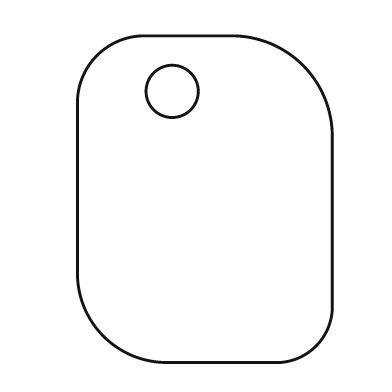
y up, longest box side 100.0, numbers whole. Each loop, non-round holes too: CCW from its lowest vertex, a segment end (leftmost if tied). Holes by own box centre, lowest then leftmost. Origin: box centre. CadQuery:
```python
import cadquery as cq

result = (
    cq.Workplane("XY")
    .moveTo(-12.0, -50.0)
    .lineTo(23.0, -50.0)
    .threePointArc((34.0, -45.0), (39.0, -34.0))
    .lineTo(39.0, 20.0)
    .threePointArc((30.0, 41.0), (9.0, 50.0))
    .lineTo(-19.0, 50.0)
    .threePointArc((-33.0, 44.0), (-39.0, 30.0))
    .lineTo(-39.0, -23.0)
    .threePointArc((-31.0, -42.0), (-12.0, -50.0))
    .close()
    .moveTo(-10.0, 33.0)
    .circle(8.0)
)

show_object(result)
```